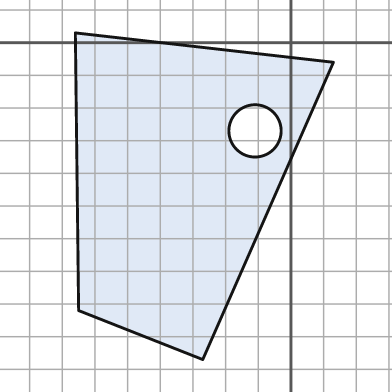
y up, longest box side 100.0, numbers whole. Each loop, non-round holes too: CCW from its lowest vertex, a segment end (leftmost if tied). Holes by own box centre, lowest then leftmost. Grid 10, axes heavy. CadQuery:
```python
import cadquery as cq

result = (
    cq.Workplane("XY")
    .moveTo(-27.0, -97.0)
    .lineTo(13.0, -6.0)
    .lineTo(-66.0, 3.0)
    .lineTo(-65.0, -82.0)
    .close()
    .moveTo(-11.0, -27.0)
    .circle(8.0)
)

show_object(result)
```